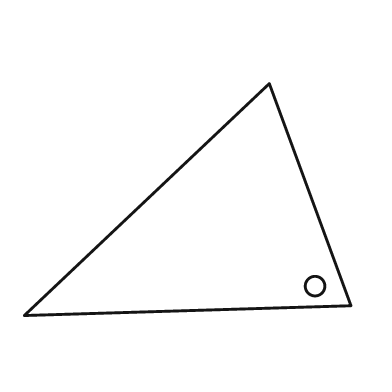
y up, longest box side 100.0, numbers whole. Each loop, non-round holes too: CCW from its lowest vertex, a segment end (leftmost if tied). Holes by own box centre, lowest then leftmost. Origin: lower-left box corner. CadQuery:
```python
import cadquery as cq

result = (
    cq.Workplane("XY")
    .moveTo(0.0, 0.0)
    .lineTo(100.0, 3.0)
    .lineTo(75.0, 71.0)
    .close()
    .moveTo(89.0, 9.0)
    .circle(3.0)
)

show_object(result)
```